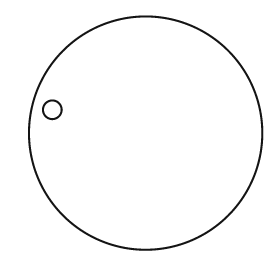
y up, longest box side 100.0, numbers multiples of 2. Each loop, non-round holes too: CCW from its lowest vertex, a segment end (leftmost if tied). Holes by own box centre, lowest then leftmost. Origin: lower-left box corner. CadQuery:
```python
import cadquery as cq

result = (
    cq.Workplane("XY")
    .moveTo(50.0, 50.0)
    .circle(50.0)
    .moveTo(10.0, 60.0)
    .circle(4.0)
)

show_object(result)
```